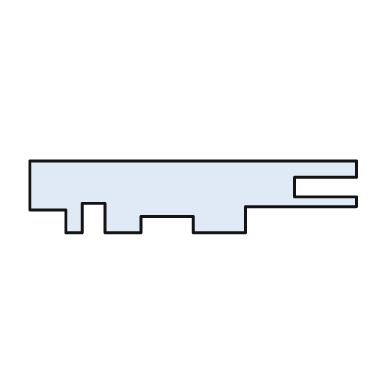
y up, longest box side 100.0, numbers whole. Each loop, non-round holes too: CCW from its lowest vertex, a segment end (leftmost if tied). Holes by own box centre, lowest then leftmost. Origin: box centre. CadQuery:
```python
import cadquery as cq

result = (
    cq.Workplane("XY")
    .moveTo(-39.0, -11.0)
    .lineTo(-34.0, -11.0)
    .lineTo(-34.0, -2.0)
    .lineTo(-27.0, -2.0)
    .lineTo(-27.0, -11.0)
    .lineTo(-16.0, -11.0)
    .lineTo(-16.0, -6.0)
    .lineTo(0.0, -6.0)
    .lineTo(0.0, -11.0)
    .lineTo(16.0, -11.0)
    .lineTo(16.0, -3.0)
    .lineTo(50.0, -3.0)
    .lineTo(50.0, 0.0)
    .lineTo(31.0, 0.0)
    .lineTo(31.0, 6.0)
    .lineTo(50.0, 6.0)
    .lineTo(50.0, 11.0)
    .lineTo(-50.0, 11.0)
    .lineTo(-50.0, -4.0)
    .lineTo(-39.0, -4.0)
    .close()
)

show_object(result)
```